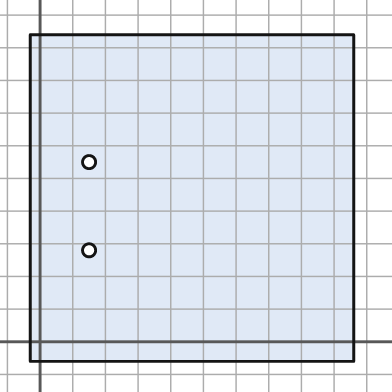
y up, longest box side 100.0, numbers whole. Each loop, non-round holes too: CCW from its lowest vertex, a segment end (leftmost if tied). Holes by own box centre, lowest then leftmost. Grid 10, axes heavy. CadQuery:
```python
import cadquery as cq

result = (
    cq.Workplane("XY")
    .moveTo(-3.0, -6.0)
    .lineTo(96.0, -6.0)
    .lineTo(96.0, 94.0)
    .lineTo(-3.0, 94.0)
    .close()
    .moveTo(15.0, 28.0)
    .circle(2.0)
    .moveTo(15.0, 55.0)
    .circle(2.0)
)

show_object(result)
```